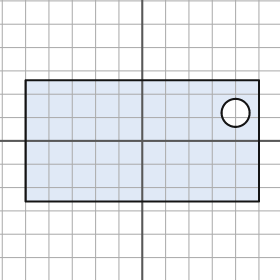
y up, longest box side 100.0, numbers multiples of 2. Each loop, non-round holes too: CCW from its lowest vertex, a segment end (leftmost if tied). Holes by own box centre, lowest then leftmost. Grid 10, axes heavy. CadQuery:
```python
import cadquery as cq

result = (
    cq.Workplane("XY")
    .moveTo(-50.0, -26.0)
    .lineTo(50.0, -26.0)
    .lineTo(50.0, 26.0)
    .lineTo(-50.0, 26.0)
    .close()
    .moveTo(40.0, 12.0)
    .circle(6.0)
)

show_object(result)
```